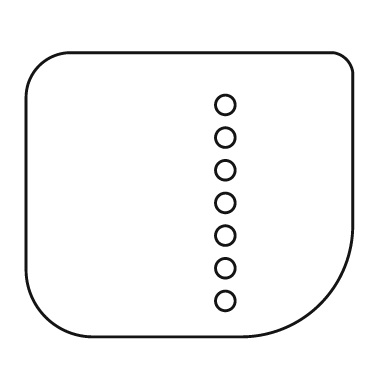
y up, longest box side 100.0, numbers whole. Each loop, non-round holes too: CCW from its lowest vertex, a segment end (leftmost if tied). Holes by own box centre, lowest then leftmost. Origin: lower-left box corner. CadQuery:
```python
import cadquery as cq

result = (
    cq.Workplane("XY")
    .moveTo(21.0, 0.0)
    .lineTo(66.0, 0.0)
    .threePointArc((90.0, 10.0), (100.0, 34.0))
    .lineTo(100.0, 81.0)
    .threePointArc((98.0, 85.0), (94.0, 87.0))
    .lineTo(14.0, 87.0)
    .threePointArc((4.0, 83.0), (0.0, 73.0))
    .lineTo(0.0, 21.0)
    .threePointArc((6.0, 6.0), (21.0, 0.0))
    .close()
    .moveTo(61.0, 11.0)
    .circle(3.0)
    .moveTo(61.0, 21.0)
    .circle(3.0)
    .moveTo(61.0, 31.0)
    .circle(3.0)
    .moveTo(61.0, 41.0)
    .circle(3.0)
    .moveTo(61.0, 51.0)
    .circle(3.0)
    .moveTo(61.0, 61.0)
    .circle(3.0)
    .moveTo(61.0, 71.0)
    .circle(3.0)
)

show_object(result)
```